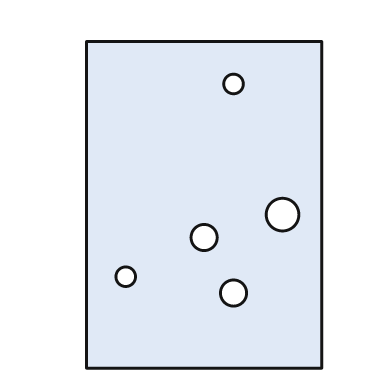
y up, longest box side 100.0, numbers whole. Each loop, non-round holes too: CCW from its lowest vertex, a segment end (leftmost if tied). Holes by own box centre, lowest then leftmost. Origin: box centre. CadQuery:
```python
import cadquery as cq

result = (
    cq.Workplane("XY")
    .moveTo(-36.0, -50.0)
    .lineTo(36.0, -50.0)
    .lineTo(36.0, 50.0)
    .lineTo(-36.0, 50.0)
    .close()
    .moveTo(9.0, -27.0)
    .circle(4.0)
    .moveTo(-24.0, -22.0)
    .circle(3.0)
    .moveTo(0.0, -10.0)
    .circle(4.0)
    .moveTo(24.0, -3.0)
    .circle(5.0)
    .moveTo(9.0, 37.0)
    .circle(3.0)
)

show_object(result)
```